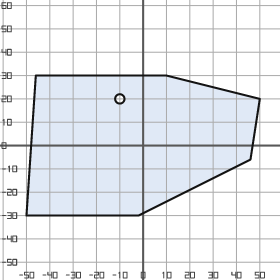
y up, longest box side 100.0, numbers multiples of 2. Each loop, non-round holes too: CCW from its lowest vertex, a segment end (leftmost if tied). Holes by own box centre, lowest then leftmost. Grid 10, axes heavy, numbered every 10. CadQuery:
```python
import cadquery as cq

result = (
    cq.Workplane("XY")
    .moveTo(-50.0, -30.0)
    .lineTo(-2.0, -30.0)
    .lineTo(46.0, -6.0)
    .lineTo(50.0, 20.0)
    .lineTo(10.0, 30.0)
    .lineTo(-46.0, 30.0)
    .close()
    .moveTo(-10.0, 20.0)
    .circle(2.0)
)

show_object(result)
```